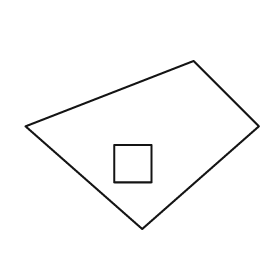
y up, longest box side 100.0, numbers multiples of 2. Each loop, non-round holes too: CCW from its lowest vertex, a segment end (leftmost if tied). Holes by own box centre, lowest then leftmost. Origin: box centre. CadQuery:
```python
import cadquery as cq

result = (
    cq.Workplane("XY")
    .moveTo(0.0, -36.0)
    .lineTo(50.0, 8.0)
    .lineTo(22.0, 36.0)
    .lineTo(-50.0, 8.0)
    .close()
    .moveTo(-12.0, -16.0)
    .lineTo(4.0, -16.0)
    .lineTo(4.0, 0.0)
    .lineTo(-12.0, 0.0)
    .close()
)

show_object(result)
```